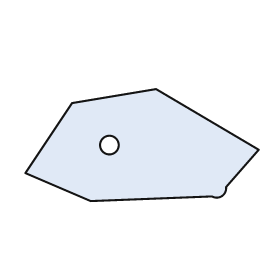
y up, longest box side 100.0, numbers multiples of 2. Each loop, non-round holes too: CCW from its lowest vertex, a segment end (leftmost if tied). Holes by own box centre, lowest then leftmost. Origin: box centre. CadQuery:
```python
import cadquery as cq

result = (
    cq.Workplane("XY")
    .moveTo(-22.0, -24.0)
    .lineTo(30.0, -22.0)
    .threePointArc((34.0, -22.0), (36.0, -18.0))
    .lineTo(50.0, -2.0)
    .lineTo(6.0, 24.0)
    .lineTo(-30.0, 18.0)
    .lineTo(-50.0, -12.0)
    .close()
    .moveTo(-14.0, 0.0)
    .circle(4.0)
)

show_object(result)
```